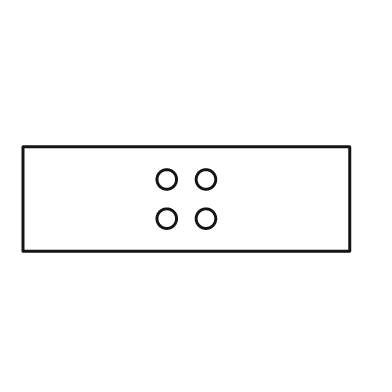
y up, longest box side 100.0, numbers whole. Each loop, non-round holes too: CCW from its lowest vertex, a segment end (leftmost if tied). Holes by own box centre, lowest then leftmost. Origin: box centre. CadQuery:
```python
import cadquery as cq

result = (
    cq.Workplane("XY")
    .moveTo(-50.0, -16.0)
    .lineTo(50.0, -16.0)
    .lineTo(50.0, 16.0)
    .lineTo(-50.0, 16.0)
    .close()
    .moveTo(-6.0, -6.0)
    .circle(3.0)
    .moveTo(6.0, -6.0)
    .circle(3.0)
    .moveTo(-6.0, 6.0)
    .circle(3.0)
    .moveTo(6.0, 6.0)
    .circle(3.0)
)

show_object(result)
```